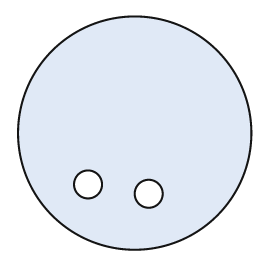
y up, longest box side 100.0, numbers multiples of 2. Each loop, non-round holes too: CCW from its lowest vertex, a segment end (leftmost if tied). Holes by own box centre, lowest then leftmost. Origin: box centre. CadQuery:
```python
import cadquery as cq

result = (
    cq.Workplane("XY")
    .moveTo(0.0, 0.0)
    .circle(50.0)
    .moveTo(6.0, -26.0)
    .circle(6.0)
    .moveTo(-20.0, -22.0)
    .circle(6.0)
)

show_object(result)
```